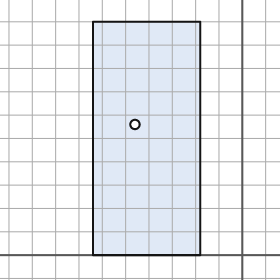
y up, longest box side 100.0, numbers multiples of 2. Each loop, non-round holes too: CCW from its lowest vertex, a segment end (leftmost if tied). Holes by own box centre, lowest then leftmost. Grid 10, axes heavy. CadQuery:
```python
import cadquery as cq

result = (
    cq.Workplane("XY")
    .moveTo(-64.0, 0.0)
    .lineTo(-18.0, 0.0)
    .lineTo(-18.0, 100.0)
    .lineTo(-64.0, 100.0)
    .close()
    .moveTo(-46.0, 56.0)
    .circle(2.0)
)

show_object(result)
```